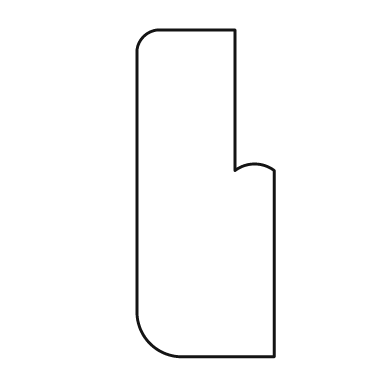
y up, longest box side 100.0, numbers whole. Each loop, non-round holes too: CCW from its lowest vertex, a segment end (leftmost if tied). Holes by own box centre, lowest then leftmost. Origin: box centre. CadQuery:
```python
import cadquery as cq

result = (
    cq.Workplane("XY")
    .moveTo(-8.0, -50.0)
    .lineTo(21.0, -50.0)
    .lineTo(21.0, 7.0)
    .threePointArc((15.0, 9.0), (9.0, 7.0))
    .lineTo(9.0, 50.0)
    .lineTo(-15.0, 50.0)
    .threePointArc((-19.0, 48.0), (-21.0, 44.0))
    .lineTo(-21.0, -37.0)
    .threePointArc((-17.0, -46.0), (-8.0, -50.0))
    .close()
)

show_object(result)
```